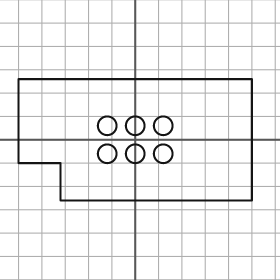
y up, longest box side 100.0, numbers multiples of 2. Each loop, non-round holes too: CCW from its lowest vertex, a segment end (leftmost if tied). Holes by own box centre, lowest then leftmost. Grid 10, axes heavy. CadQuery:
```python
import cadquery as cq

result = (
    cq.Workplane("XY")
    .moveTo(-32.0, -26.0)
    .lineTo(50.0, -26.0)
    .lineTo(50.0, 26.0)
    .lineTo(-50.0, 26.0)
    .lineTo(-50.0, -10.0)
    .lineTo(-32.0, -10.0)
    .close()
    .moveTo(-12.0, -6.0)
    .circle(4.0)
    .moveTo(0.0, -6.0)
    .circle(4.0)
    .moveTo(12.0, -6.0)
    .circle(4.0)
    .moveTo(-12.0, 6.0)
    .circle(4.0)
    .moveTo(0.0, 6.0)
    .circle(4.0)
    .moveTo(12.0, 6.0)
    .circle(4.0)
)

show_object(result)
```